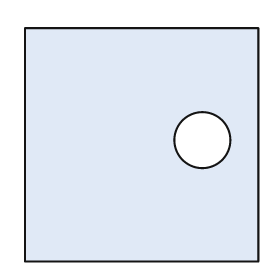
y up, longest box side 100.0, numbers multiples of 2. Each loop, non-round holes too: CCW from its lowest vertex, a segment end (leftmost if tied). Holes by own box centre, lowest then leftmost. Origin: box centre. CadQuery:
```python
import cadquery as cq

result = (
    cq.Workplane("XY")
    .moveTo(-50.0, -50.0)
    .lineTo(50.0, -50.0)
    .lineTo(50.0, 50.0)
    .lineTo(-50.0, 50.0)
    .close()
    .moveTo(26.0, 2.0)
    .circle(12.0)
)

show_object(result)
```